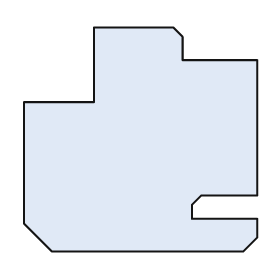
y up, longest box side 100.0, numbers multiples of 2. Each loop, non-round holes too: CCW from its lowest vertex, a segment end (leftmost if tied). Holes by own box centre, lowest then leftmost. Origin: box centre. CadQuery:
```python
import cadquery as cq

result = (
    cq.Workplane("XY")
    .moveTo(-38.0, -48.0)
    .lineTo(44.0, -48.0)
    .lineTo(50.0, -42.0)
    .lineTo(50.0, -34.0)
    .lineTo(22.0, -34.0)
    .lineTo(22.0, -28.0)
    .lineTo(26.0, -24.0)
    .lineTo(50.0, -24.0)
    .lineTo(50.0, 34.0)
    .lineTo(18.0, 34.0)
    .lineTo(18.0, 44.0)
    .lineTo(14.0, 48.0)
    .lineTo(-20.0, 48.0)
    .lineTo(-20.0, 16.0)
    .lineTo(-50.0, 16.0)
    .lineTo(-50.0, -36.0)
    .close()
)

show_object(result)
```